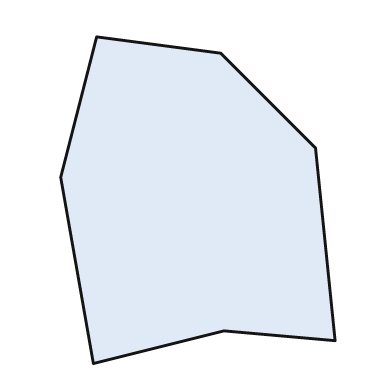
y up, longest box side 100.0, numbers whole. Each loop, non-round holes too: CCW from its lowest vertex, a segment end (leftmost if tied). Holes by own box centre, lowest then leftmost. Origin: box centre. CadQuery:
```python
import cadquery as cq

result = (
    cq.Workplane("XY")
    .moveTo(-32.0, -50.0)
    .lineTo(8.0, -40.0)
    .lineTo(42.0, -43.0)
    .lineTo(36.0, 16.0)
    .lineTo(7.0, 45.0)
    .lineTo(-31.0, 50.0)
    .lineTo(-42.0, 7.0)
    .close()
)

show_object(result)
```